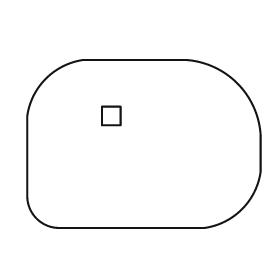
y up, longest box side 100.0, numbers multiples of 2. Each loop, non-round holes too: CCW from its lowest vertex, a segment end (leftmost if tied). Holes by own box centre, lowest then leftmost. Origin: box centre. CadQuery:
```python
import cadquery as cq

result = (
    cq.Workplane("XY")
    .moveTo(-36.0, -36.0)
    .lineTo(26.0, -36.0)
    .threePointArc((42.0, -28.0), (50.0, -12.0))
    .lineTo(50.0, 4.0)
    .threePointArc((40.0, 26.0), (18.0, 36.0))
    .lineTo(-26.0, 36.0)
    .threePointArc((-42.0, 28.0), (-50.0, 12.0))
    .lineTo(-50.0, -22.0)
    .threePointArc((-46.0, -32.0), (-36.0, -36.0))
    .close()
    .moveTo(-18.0, 8.0)
    .lineTo(-10.0, 8.0)
    .lineTo(-10.0, 16.0)
    .lineTo(-18.0, 16.0)
    .close()
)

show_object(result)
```